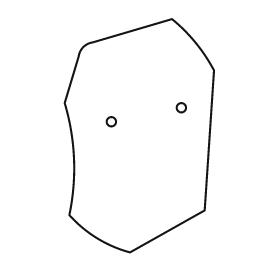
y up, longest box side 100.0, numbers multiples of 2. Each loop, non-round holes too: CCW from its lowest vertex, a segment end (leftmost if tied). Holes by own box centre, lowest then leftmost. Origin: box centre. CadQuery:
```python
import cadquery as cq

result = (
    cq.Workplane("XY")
    .moveTo(-4.0, -50.0)
    .lineTo(28.0, -32.0)
    .lineTo(32.0, 28.0)
    .threePointArc((24.0, 40.0), (14.0, 50.0))
    .lineTo(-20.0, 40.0)
    .threePointArc((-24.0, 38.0), (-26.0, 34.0))
    .lineTo(-32.0, 14.0)
    .threePointArc((-28.0, -10.0), (-30.0, -34.0))
    .threePointArc((-18.0, -44.0), (-4.0, -50.0))
    .close()
    .moveTo(-12.0, 6.0)
    .circle(2.0)
    .moveTo(18.0, 12.0)
    .circle(2.0)
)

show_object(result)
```